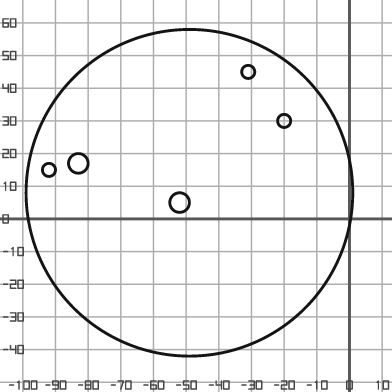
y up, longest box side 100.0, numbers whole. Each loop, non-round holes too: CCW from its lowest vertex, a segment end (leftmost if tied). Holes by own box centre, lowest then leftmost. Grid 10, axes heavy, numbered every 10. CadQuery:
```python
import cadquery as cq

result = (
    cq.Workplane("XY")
    .moveTo(-49.0, 8.0)
    .circle(50.0)
    .moveTo(-52.0, 5.0)
    .circle(3.0)
    .moveTo(-92.0, 15.0)
    .circle(2.0)
    .moveTo(-83.0, 17.0)
    .circle(3.0)
    .moveTo(-20.0, 30.0)
    .circle(2.0)
    .moveTo(-31.0, 45.0)
    .circle(2.0)
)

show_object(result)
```